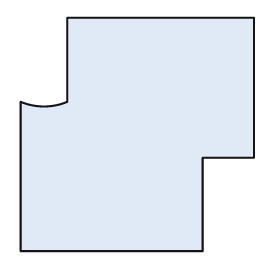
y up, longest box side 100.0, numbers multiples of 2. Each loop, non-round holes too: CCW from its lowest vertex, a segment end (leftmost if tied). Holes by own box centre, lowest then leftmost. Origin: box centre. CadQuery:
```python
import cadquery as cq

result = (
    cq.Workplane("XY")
    .moveTo(-50.0, -50.0)
    .lineTo(28.0, -50.0)
    .lineTo(28.0, -10.0)
    .lineTo(50.0, -10.0)
    .lineTo(50.0, 50.0)
    .lineTo(-30.0, 50.0)
    .lineTo(-30.0, 14.0)
    .threePointArc((-40.0, 12.0), (-50.0, 14.0))
    .close()
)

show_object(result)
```